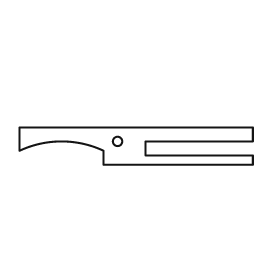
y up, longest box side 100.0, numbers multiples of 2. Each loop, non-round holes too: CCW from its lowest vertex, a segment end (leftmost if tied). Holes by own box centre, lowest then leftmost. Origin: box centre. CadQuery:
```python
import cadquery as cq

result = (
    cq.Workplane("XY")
    .moveTo(-14.0, -8.0)
    .lineTo(50.0, -8.0)
    .lineTo(50.0, -4.0)
    .lineTo(4.0, -4.0)
    .lineTo(4.0, 2.0)
    .lineTo(50.0, 2.0)
    .lineTo(50.0, 8.0)
    .lineTo(-50.0, 8.0)
    .lineTo(-50.0, -2.0)
    .threePointArc((-32.0, 2.0), (-14.0, -2.0))
    .close()
    .moveTo(-8.0, 2.0)
    .circle(2.0)
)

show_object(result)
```